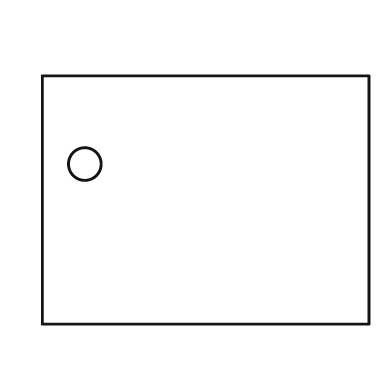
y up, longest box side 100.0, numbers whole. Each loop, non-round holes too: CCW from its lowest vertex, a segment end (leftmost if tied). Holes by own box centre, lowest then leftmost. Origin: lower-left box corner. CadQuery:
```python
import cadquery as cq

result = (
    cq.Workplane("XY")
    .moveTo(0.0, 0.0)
    .lineTo(100.0, 0.0)
    .lineTo(100.0, 76.0)
    .lineTo(0.0, 76.0)
    .close()
    .moveTo(13.0, 49.0)
    .circle(5.0)
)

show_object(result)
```